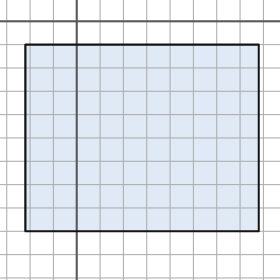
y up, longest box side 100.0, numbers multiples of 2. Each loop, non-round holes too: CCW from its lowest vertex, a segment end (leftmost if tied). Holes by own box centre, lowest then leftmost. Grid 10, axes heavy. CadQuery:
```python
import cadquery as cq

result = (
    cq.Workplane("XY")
    .moveTo(-22.0, -90.0)
    .lineTo(78.0, -90.0)
    .lineTo(78.0, -10.0)
    .lineTo(-22.0, -10.0)
    .close()
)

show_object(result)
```